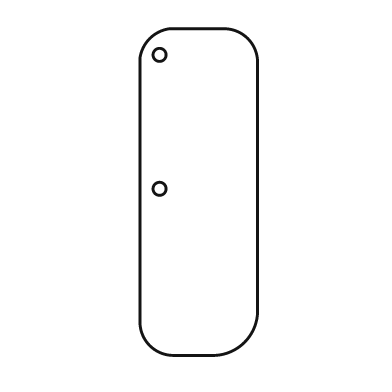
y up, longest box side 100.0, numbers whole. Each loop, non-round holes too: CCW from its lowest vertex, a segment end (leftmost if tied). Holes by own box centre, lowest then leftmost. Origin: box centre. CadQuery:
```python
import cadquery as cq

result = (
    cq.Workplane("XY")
    .moveTo(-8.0, -50.0)
    .lineTo(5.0, -50.0)
    .threePointArc((14.0, -46.0), (18.0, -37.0))
    .lineTo(18.0, 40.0)
    .threePointArc((15.0, 47.0), (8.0, 50.0))
    .lineTo(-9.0, 50.0)
    .threePointArc((-15.0, 47.0), (-18.0, 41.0))
    .lineTo(-18.0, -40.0)
    .threePointArc((-15.0, -47.0), (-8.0, -50.0))
    .close()
    .moveTo(-12.0, 1.0)
    .circle(2.0)
    .moveTo(-12.0, 42.0)
    .circle(2.0)
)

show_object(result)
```